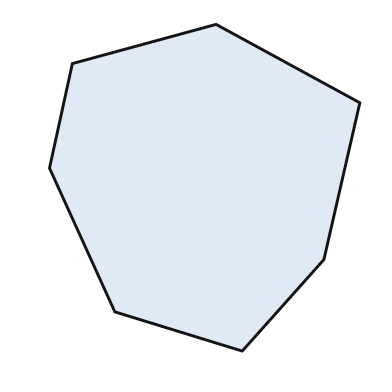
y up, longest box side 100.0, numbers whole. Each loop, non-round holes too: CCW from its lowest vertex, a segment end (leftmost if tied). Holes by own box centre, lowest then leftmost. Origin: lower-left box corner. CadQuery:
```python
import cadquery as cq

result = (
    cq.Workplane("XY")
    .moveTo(59.0, 0.0)
    .lineTo(84.0, 28.0)
    .lineTo(95.0, 76.0)
    .lineTo(51.0, 100.0)
    .lineTo(7.0, 88.0)
    .lineTo(0.0, 56.0)
    .lineTo(20.0, 12.0)
    .close()
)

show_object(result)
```